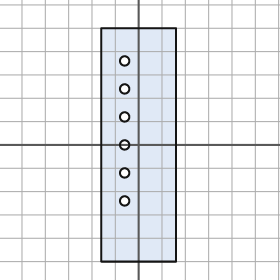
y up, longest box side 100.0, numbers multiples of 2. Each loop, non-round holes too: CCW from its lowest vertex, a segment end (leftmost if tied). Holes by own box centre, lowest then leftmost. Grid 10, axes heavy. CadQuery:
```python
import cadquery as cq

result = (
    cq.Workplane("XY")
    .moveTo(-16.0, -50.0)
    .lineTo(16.0, -50.0)
    .lineTo(16.0, 50.0)
    .lineTo(-16.0, 50.0)
    .close()
    .moveTo(-6.0, -24.0)
    .circle(2.0)
    .moveTo(-6.0, -12.0)
    .circle(2.0)
    .moveTo(-6.0, 0.0)
    .circle(2.0)
    .moveTo(-6.0, 12.0)
    .circle(2.0)
    .moveTo(-6.0, 24.0)
    .circle(2.0)
    .moveTo(-6.0, 36.0)
    .circle(2.0)
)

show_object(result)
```